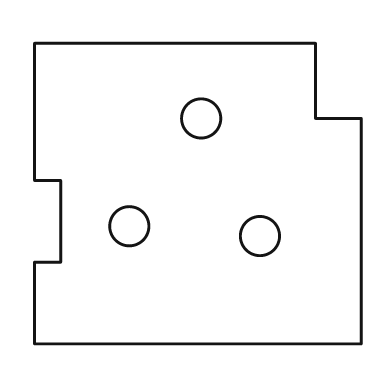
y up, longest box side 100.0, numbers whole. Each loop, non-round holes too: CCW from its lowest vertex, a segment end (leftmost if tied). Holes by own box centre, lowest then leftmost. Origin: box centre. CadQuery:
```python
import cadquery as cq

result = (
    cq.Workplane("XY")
    .moveTo(-50.0, -46.0)
    .lineTo(50.0, -46.0)
    .lineTo(50.0, 23.0)
    .lineTo(36.0, 23.0)
    .lineTo(36.0, 46.0)
    .lineTo(-50.0, 46.0)
    .lineTo(-50.0, 4.0)
    .lineTo(-42.0, 4.0)
    .lineTo(-42.0, -21.0)
    .lineTo(-50.0, -21.0)
    .close()
    .moveTo(19.0, -13.0)
    .circle(6.0)
    .moveTo(-21.0, -10.0)
    .circle(6.0)
    .moveTo(1.0, 23.0)
    .circle(6.0)
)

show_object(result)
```